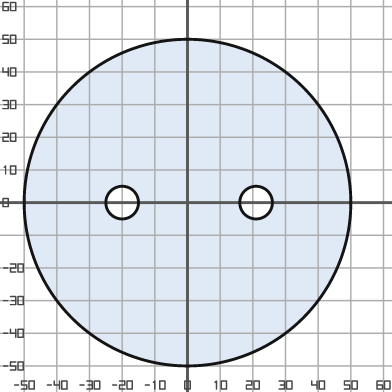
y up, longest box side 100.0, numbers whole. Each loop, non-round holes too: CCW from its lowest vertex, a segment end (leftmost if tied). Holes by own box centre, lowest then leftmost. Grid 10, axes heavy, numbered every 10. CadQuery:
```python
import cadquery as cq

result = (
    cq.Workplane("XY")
    .moveTo(0.0, 0.0)
    .circle(50.0)
    .moveTo(-20.0, 0.0)
    .circle(5.0)
    .moveTo(21.0, 0.0)
    .circle(5.0)
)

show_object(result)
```